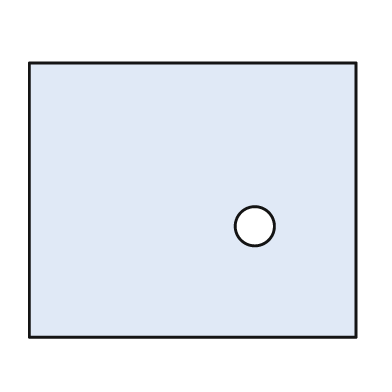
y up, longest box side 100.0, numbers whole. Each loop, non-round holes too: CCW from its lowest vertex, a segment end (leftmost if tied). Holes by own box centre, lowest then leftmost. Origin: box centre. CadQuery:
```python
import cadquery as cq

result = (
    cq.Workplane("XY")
    .moveTo(-50.0, -42.0)
    .lineTo(50.0, -42.0)
    .lineTo(50.0, 42.0)
    .lineTo(-50.0, 42.0)
    .close()
    .moveTo(19.0, -8.0)
    .circle(6.0)
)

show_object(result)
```